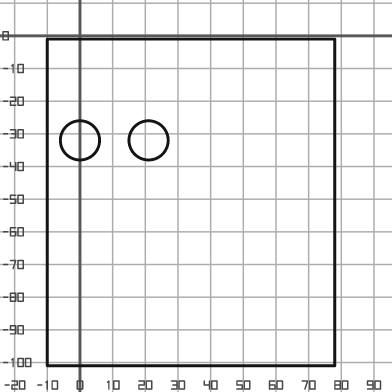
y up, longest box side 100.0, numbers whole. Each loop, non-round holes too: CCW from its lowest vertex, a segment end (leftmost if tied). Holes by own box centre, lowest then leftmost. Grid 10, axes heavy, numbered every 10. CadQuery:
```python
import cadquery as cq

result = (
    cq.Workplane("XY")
    .moveTo(-10.0, -101.0)
    .lineTo(78.0, -101.0)
    .lineTo(78.0, -1.0)
    .lineTo(-10.0, -1.0)
    .close()
    .moveTo(0.0, -32.0)
    .circle(6.0)
    .moveTo(21.0, -32.0)
    .circle(6.0)
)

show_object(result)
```